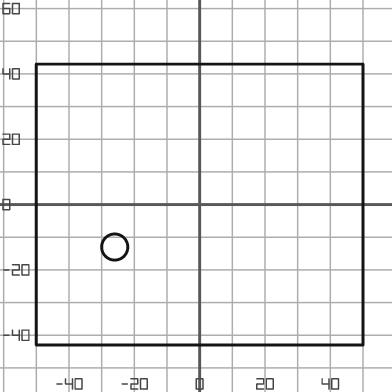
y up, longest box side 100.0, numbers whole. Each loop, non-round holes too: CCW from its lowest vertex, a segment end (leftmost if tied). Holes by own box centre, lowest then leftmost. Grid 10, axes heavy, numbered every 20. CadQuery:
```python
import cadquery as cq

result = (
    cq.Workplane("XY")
    .moveTo(-50.0, -43.0)
    .lineTo(50.0, -43.0)
    .lineTo(50.0, 43.0)
    .lineTo(-50.0, 43.0)
    .close()
    .moveTo(-26.0, -13.0)
    .circle(4.0)
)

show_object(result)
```